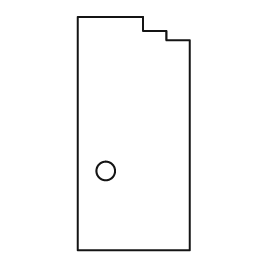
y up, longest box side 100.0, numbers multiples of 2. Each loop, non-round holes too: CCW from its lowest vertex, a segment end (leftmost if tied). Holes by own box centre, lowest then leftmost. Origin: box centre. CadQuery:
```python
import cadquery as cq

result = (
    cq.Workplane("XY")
    .moveTo(-24.0, -50.0)
    .lineTo(24.0, -50.0)
    .lineTo(24.0, 40.0)
    .lineTo(14.0, 40.0)
    .lineTo(14.0, 44.0)
    .lineTo(4.0, 44.0)
    .lineTo(4.0, 50.0)
    .lineTo(-24.0, 50.0)
    .close()
    .moveTo(-12.0, -16.0)
    .circle(4.0)
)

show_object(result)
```